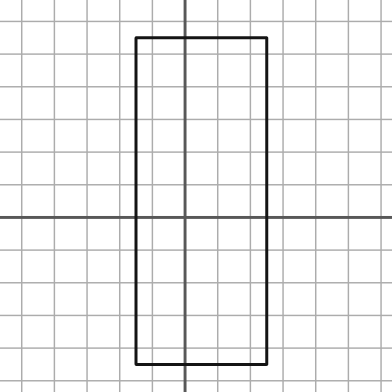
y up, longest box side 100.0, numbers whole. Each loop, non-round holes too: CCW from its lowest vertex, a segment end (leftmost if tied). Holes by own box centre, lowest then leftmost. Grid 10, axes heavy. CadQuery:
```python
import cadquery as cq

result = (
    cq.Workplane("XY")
    .moveTo(-15.0, -45.0)
    .lineTo(25.0, -45.0)
    .lineTo(25.0, 55.0)
    .lineTo(-15.0, 55.0)
    .close()
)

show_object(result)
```